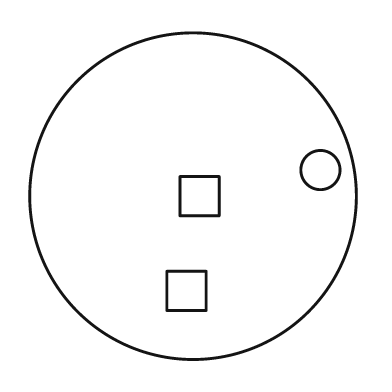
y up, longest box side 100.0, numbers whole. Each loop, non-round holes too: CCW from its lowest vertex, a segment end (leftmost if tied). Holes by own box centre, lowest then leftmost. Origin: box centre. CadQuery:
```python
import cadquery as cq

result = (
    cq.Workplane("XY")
    .moveTo(0.0, 0.0)
    .circle(50.0)
    .moveTo(-8.0, -35.0)
    .lineTo(4.0, -35.0)
    .lineTo(4.0, -23.0)
    .lineTo(-8.0, -23.0)
    .close()
    .moveTo(-4.0, -6.0)
    .lineTo(8.0, -6.0)
    .lineTo(8.0, 6.0)
    .lineTo(-4.0, 6.0)
    .close()
    .moveTo(39.0, 8.0)
    .circle(6.0)
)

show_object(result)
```